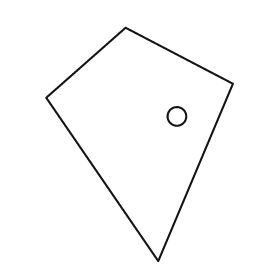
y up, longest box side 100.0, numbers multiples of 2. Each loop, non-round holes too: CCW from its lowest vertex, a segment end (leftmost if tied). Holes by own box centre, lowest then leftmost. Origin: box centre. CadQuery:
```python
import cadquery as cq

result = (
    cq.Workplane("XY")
    .moveTo(8.0, -50.0)
    .lineTo(40.0, 26.0)
    .lineTo(-6.0, 50.0)
    .lineTo(-40.0, 20.0)
    .close()
    .moveTo(16.0, 12.0)
    .circle(4.0)
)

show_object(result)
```